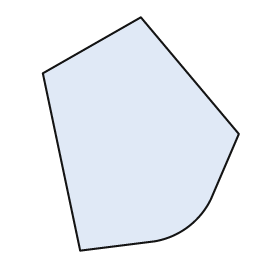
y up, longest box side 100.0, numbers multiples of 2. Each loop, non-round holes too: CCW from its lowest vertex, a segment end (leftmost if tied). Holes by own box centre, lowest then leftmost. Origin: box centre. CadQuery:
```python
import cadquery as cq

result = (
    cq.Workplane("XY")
    .moveTo(-26.0, -50.0)
    .lineTo(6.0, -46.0)
    .threePointArc((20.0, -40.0), (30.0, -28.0))
    .lineTo(42.0, 0.0)
    .lineTo(0.0, 50.0)
    .lineTo(-42.0, 26.0)
    .close()
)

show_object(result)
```